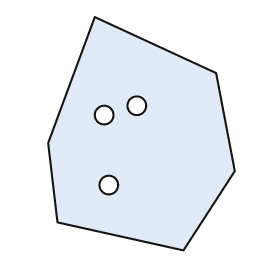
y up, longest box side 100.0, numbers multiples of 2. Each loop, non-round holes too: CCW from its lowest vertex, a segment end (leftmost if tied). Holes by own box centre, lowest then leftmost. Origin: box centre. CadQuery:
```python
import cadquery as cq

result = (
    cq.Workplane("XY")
    .moveTo(18.0, -50.0)
    .lineTo(40.0, -16.0)
    .lineTo(32.0, 26.0)
    .lineTo(-20.0, 50.0)
    .lineTo(-40.0, -4.0)
    .lineTo(-36.0, -38.0)
    .close()
    .moveTo(-14.0, -22.0)
    .circle(4.0)
    .moveTo(-16.0, 8.0)
    .circle(4.0)
    .moveTo(-2.0, 12.0)
    .circle(4.0)
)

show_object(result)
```